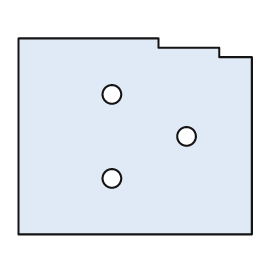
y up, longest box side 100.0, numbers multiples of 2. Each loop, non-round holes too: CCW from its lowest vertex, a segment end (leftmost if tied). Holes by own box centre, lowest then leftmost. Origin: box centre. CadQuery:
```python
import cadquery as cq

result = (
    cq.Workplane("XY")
    .moveTo(-50.0, -42.0)
    .lineTo(50.0, -42.0)
    .lineTo(50.0, 34.0)
    .lineTo(36.0, 34.0)
    .lineTo(36.0, 38.0)
    .lineTo(10.0, 38.0)
    .lineTo(10.0, 42.0)
    .lineTo(-50.0, 42.0)
    .close()
    .moveTo(-10.0, -18.0)
    .circle(4.0)
    .moveTo(22.0, 0.0)
    .circle(4.0)
    .moveTo(-10.0, 18.0)
    .circle(4.0)
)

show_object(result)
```